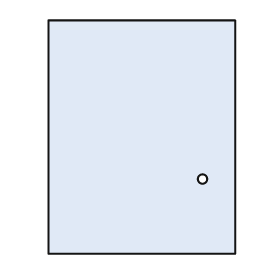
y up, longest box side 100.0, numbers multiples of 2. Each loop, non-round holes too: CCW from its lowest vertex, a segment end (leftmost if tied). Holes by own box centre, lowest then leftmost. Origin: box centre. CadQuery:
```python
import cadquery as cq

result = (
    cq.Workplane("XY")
    .moveTo(-40.0, -50.0)
    .lineTo(40.0, -50.0)
    .lineTo(40.0, 50.0)
    .lineTo(-40.0, 50.0)
    .close()
    .moveTo(26.0, -18.0)
    .circle(2.0)
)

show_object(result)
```